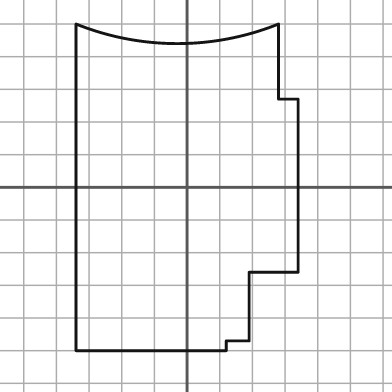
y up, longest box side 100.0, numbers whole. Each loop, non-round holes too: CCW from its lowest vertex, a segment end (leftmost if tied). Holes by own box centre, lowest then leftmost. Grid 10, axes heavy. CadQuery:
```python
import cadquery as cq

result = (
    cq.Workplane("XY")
    .moveTo(-34.0, -50.0)
    .lineTo(12.0, -50.0)
    .lineTo(12.0, -47.0)
    .lineTo(19.0, -47.0)
    .lineTo(19.0, -26.0)
    .lineTo(34.0, -26.0)
    .lineTo(34.0, 27.0)
    .lineTo(28.0, 27.0)
    .lineTo(28.0, 50.0)
    .threePointArc((-3.0, 44.0), (-34.0, 50.0))
    .close()
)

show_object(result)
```